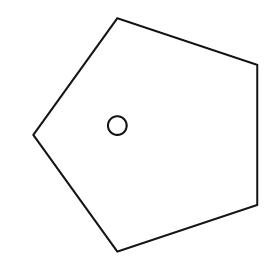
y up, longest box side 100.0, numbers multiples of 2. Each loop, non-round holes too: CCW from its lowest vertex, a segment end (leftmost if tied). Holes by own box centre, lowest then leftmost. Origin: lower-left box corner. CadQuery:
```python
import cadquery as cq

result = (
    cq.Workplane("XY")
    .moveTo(36.0, 0.0)
    .lineTo(96.0, 20.0)
    .lineTo(96.0, 80.0)
    .lineTo(36.0, 100.0)
    .lineTo(0.0, 50.0)
    .close()
    .moveTo(36.0, 54.0)
    .circle(4.0)
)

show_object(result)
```